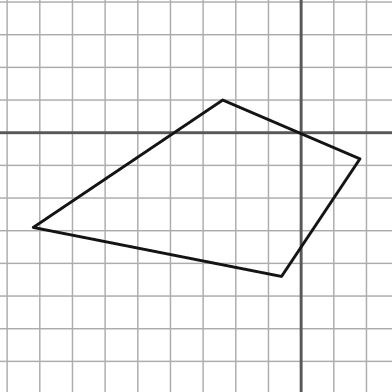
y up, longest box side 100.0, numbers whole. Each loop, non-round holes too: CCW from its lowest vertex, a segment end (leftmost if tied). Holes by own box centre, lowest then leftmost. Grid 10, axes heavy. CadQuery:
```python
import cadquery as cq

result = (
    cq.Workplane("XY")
    .moveTo(-6.0, -44.0)
    .lineTo(18.0, -8.0)
    .lineTo(-24.0, 10.0)
    .lineTo(-82.0, -29.0)
    .close()
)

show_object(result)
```